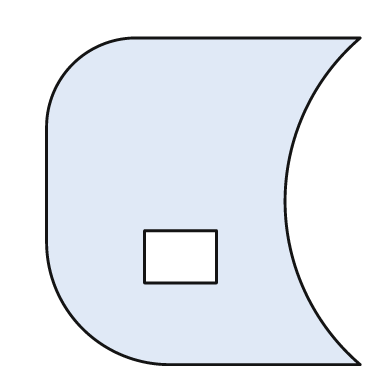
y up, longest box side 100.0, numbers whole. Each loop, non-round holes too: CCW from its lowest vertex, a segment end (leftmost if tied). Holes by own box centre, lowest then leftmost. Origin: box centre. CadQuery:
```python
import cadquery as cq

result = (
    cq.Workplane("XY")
    .moveTo(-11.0, -50.0)
    .lineTo(48.0, -50.0)
    .threePointArc((25.0, 0.0), (48.0, 50.0))
    .lineTo(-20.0, 50.0)
    .threePointArc((-40.0, 42.0), (-48.0, 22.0))
    .lineTo(-48.0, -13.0)
    .threePointArc((-37.0, -39.0), (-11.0, -50.0))
    .close()
    .moveTo(-18.0, -25.0)
    .lineTo(4.0, -25.0)
    .lineTo(4.0, -9.0)
    .lineTo(-18.0, -9.0)
    .close()
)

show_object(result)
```